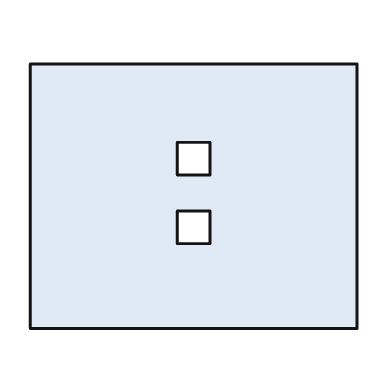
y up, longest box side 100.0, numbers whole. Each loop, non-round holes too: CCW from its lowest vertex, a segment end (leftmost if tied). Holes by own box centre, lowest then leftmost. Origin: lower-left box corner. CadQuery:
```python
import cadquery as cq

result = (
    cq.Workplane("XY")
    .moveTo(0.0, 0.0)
    .lineTo(100.0, 0.0)
    .lineTo(100.0, 81.0)
    .lineTo(0.0, 81.0)
    .close()
    .moveTo(45.0, 26.0)
    .lineTo(55.0, 26.0)
    .lineTo(55.0, 36.0)
    .lineTo(45.0, 36.0)
    .close()
    .moveTo(45.0, 47.0)
    .lineTo(55.0, 47.0)
    .lineTo(55.0, 57.0)
    .lineTo(45.0, 57.0)
    .close()
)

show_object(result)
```